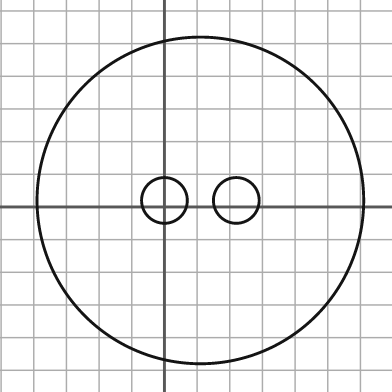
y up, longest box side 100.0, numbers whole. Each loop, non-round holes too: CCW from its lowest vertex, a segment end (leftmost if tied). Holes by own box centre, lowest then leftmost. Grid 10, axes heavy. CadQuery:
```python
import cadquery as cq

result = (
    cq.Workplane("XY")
    .moveTo(11.0, 2.0)
    .circle(50.0)
    .moveTo(0.0, 2.0)
    .circle(7.0)
    .moveTo(22.0, 2.0)
    .circle(7.0)
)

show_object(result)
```